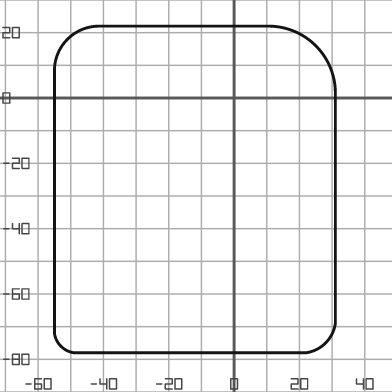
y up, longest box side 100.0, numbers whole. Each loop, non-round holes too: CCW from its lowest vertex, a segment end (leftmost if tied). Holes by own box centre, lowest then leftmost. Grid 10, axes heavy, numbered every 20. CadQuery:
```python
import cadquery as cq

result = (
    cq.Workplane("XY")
    .moveTo(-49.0, -78.0)
    .lineTo(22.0, -78.0)
    .threePointArc((28.0, -75.0), (31.0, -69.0))
    .lineTo(31.0, 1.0)
    .threePointArc((25.0, 16.0), (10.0, 22.0))
    .lineTo(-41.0, 22.0)
    .threePointArc((-51.0, 18.0), (-55.0, 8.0))
    .lineTo(-55.0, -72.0)
    .threePointArc((-53.0, -76.0), (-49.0, -78.0))
    .close()
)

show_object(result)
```